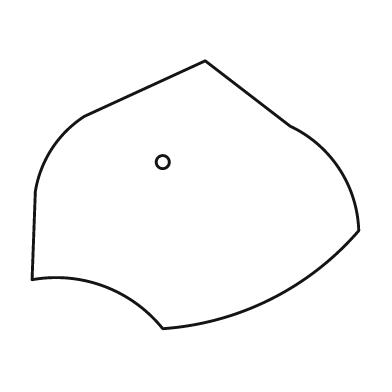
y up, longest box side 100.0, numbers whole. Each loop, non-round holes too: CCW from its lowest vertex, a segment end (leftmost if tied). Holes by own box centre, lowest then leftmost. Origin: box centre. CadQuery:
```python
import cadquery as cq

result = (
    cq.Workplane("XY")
    .moveTo(-10.0, -41.0)
    .threePointArc((23.0, -32.0), (50.0, -11.0))
    .threePointArc((44.0, 8.0), (29.0, 21.0))
    .lineTo(3.0, 41.0)
    .lineTo(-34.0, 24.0)
    .threePointArc((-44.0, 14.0), (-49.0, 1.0))
    .lineTo(-50.0, -26.0)
    .threePointArc((-28.0, -28.0), (-10.0, -41.0))
    .close()
    .moveTo(-10.0, 10.0)
    .circle(2.0)
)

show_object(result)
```